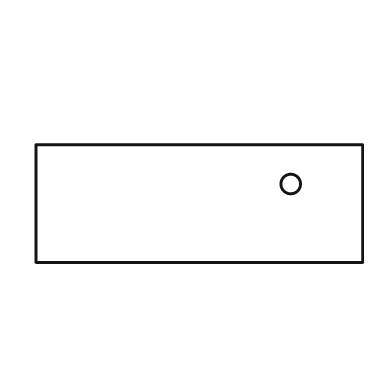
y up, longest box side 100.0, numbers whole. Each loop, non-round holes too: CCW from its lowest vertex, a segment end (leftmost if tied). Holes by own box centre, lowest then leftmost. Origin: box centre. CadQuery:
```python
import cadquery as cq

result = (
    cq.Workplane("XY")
    .moveTo(-50.0, -18.0)
    .lineTo(50.0, -18.0)
    .lineTo(50.0, 18.0)
    .lineTo(-50.0, 18.0)
    .close()
    .moveTo(28.0, 6.0)
    .circle(3.0)
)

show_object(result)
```